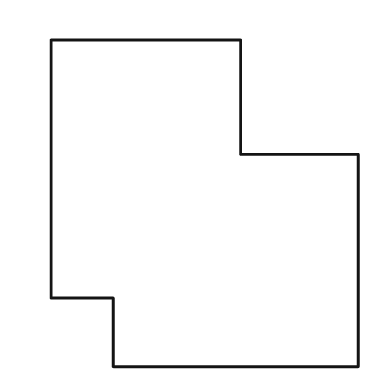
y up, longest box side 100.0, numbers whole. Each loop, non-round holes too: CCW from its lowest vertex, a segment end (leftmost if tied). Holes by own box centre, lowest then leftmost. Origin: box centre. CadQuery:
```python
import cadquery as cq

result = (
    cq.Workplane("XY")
    .moveTo(-28.0, -50.0)
    .lineTo(47.0, -50.0)
    .lineTo(47.0, 15.0)
    .lineTo(11.0, 15.0)
    .lineTo(11.0, 50.0)
    .lineTo(-47.0, 50.0)
    .lineTo(-47.0, -29.0)
    .lineTo(-28.0, -29.0)
    .close()
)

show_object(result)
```